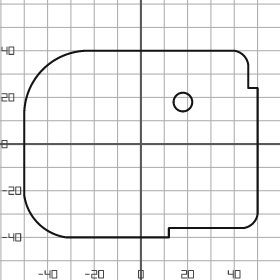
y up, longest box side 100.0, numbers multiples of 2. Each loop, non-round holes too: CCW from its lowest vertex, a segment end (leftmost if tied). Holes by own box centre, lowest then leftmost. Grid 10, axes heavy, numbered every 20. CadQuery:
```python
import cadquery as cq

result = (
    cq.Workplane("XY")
    .moveTo(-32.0, -40.0)
    .lineTo(12.0, -40.0)
    .lineTo(12.0, -36.0)
    .lineTo(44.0, -36.0)
    .threePointArc((48.0, -34.0), (50.0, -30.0))
    .lineTo(50.0, 24.0)
    .lineTo(46.0, 24.0)
    .lineTo(46.0, 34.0)
    .threePointArc((44.0, 38.0), (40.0, 40.0))
    .lineTo(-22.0, 40.0)
    .threePointArc((-42.0, 32.0), (-50.0, 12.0))
    .lineTo(-50.0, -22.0)
    .threePointArc((-44.0, -34.0), (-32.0, -40.0))
    .close()
    .moveTo(18.0, 18.0)
    .circle(4.0)
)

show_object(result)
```